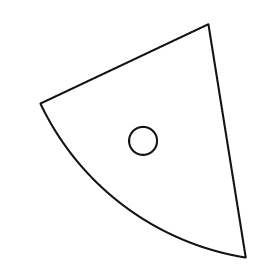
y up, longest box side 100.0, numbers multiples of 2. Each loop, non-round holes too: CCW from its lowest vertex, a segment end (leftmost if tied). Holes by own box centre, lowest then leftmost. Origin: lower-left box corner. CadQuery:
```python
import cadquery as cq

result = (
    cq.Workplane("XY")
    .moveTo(88.0, 0.0)
    .lineTo(72.0, 100.0)
    .lineTo(0.0, 66.0)
    .threePointArc((36.0, 22.0), (88.0, 0.0))
    .close()
    .moveTo(44.0, 50.0)
    .circle(6.0)
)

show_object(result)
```